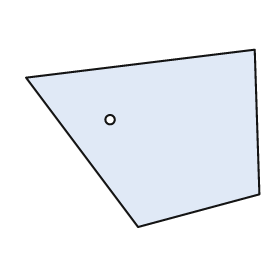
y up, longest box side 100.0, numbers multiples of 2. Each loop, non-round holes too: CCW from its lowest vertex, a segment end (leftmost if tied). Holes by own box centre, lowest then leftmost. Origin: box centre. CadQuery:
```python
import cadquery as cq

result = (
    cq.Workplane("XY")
    .moveTo(-2.0, -38.0)
    .lineTo(50.0, -24.0)
    .lineTo(48.0, 38.0)
    .lineTo(-50.0, 26.0)
    .close()
    .moveTo(-14.0, 8.0)
    .circle(2.0)
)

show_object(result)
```